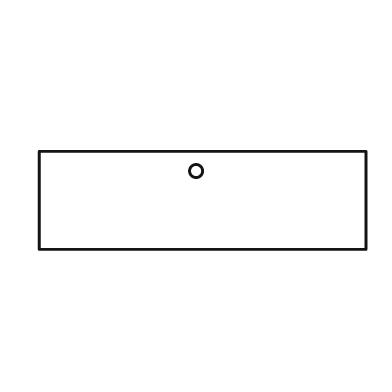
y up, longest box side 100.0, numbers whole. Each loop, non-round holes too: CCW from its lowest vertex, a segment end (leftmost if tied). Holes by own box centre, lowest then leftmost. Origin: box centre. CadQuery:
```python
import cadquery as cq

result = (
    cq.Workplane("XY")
    .moveTo(-50.0, -15.0)
    .lineTo(50.0, -15.0)
    .lineTo(50.0, 15.0)
    .lineTo(-50.0, 15.0)
    .close()
    .moveTo(-2.0, 9.0)
    .circle(2.0)
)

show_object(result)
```